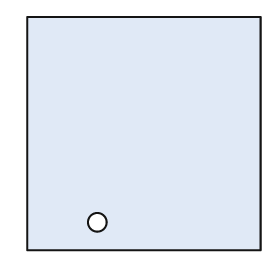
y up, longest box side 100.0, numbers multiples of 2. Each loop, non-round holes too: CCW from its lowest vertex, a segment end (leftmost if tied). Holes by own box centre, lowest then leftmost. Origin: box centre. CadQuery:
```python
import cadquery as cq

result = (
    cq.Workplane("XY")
    .moveTo(-50.0, -50.0)
    .lineTo(50.0, -50.0)
    .lineTo(50.0, 50.0)
    .lineTo(-50.0, 50.0)
    .close()
    .moveTo(-20.0, -38.0)
    .circle(4.0)
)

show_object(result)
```